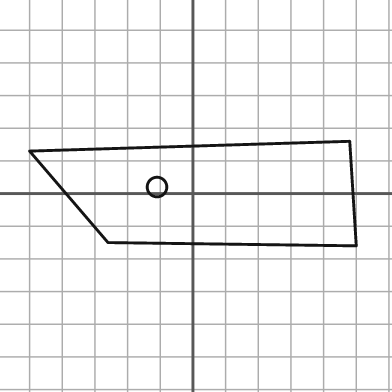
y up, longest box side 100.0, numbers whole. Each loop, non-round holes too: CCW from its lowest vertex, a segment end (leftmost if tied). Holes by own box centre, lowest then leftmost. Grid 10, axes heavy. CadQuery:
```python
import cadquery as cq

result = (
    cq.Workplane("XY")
    .moveTo(50.0, -16.0)
    .lineTo(48.0, 16.0)
    .lineTo(-50.0, 13.0)
    .lineTo(-26.0, -15.0)
    .close()
    .moveTo(-11.0, 2.0)
    .circle(3.0)
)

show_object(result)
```